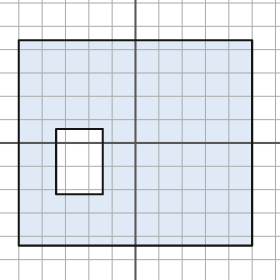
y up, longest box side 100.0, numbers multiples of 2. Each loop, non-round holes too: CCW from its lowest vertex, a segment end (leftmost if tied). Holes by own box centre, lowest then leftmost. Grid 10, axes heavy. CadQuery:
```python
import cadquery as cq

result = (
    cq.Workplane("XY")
    .moveTo(-50.0, -44.0)
    .lineTo(50.0, -44.0)
    .lineTo(50.0, 44.0)
    .lineTo(-50.0, 44.0)
    .close()
    .moveTo(-34.0, -22.0)
    .lineTo(-14.0, -22.0)
    .lineTo(-14.0, 6.0)
    .lineTo(-34.0, 6.0)
    .close()
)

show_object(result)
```